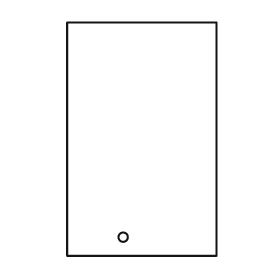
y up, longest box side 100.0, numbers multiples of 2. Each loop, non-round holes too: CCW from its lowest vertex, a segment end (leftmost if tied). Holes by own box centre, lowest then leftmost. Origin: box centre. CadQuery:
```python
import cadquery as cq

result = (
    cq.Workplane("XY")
    .moveTo(-32.0, -50.0)
    .lineTo(32.0, -50.0)
    .lineTo(32.0, 50.0)
    .lineTo(-32.0, 50.0)
    .close()
    .moveTo(-8.0, -42.0)
    .circle(2.0)
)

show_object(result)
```